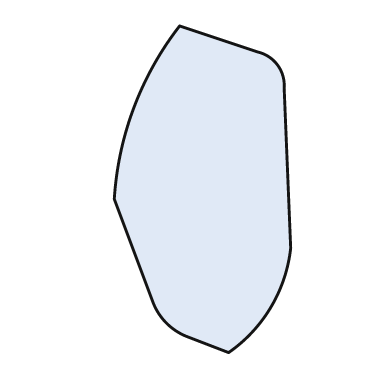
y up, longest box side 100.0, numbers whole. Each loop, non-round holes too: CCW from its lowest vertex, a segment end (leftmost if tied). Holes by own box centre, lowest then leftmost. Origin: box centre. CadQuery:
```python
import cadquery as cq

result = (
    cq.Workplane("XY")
    .moveTo(8.0, -50.0)
    .threePointArc((21.0, -36.0), (27.0, -18.0))
    .lineTo(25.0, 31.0)
    .threePointArc((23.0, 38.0), (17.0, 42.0))
    .lineTo(-7.0, 50.0)
    .threePointArc((-21.0, 25.0), (-27.0, -3.0))
    .lineTo(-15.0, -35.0)
    .threePointArc((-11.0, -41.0), (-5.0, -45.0))
    .close()
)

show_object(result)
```